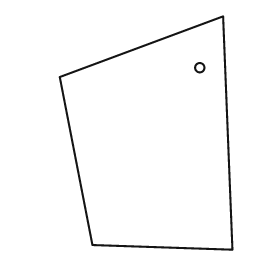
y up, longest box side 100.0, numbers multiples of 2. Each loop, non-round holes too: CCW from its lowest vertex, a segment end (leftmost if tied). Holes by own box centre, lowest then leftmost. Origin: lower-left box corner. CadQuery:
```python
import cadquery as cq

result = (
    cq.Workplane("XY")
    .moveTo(74.0, 0.0)
    .lineTo(70.0, 100.0)
    .lineTo(0.0, 74.0)
    .lineTo(14.0, 2.0)
    .close()
    .moveTo(60.0, 78.0)
    .circle(2.0)
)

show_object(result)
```